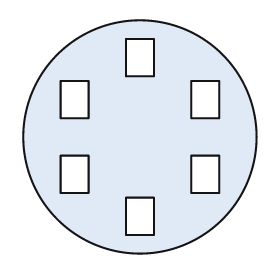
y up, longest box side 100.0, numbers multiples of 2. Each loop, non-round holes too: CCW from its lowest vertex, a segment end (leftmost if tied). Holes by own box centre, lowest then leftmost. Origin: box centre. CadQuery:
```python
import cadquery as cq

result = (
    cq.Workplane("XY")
    .moveTo(0.0, 0.0)
    .circle(50.0)
    .moveTo(-6.0, -42.0)
    .lineTo(6.0, -42.0)
    .lineTo(6.0, -26.0)
    .lineTo(-6.0, -26.0)
    .close()
    .moveTo(-34.0, -24.0)
    .lineTo(-22.0, -24.0)
    .lineTo(-22.0, -8.0)
    .lineTo(-34.0, -8.0)
    .close()
    .moveTo(22.0, -24.0)
    .lineTo(34.0, -24.0)
    .lineTo(34.0, -8.0)
    .lineTo(22.0, -8.0)
    .close()
    .moveTo(-34.0, 8.0)
    .lineTo(-22.0, 8.0)
    .lineTo(-22.0, 24.0)
    .lineTo(-34.0, 24.0)
    .close()
    .moveTo(22.0, 8.0)
    .lineTo(34.0, 8.0)
    .lineTo(34.0, 24.0)
    .lineTo(22.0, 24.0)
    .close()
    .moveTo(-6.0, 26.0)
    .lineTo(6.0, 26.0)
    .lineTo(6.0, 42.0)
    .lineTo(-6.0, 42.0)
    .close()
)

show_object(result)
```